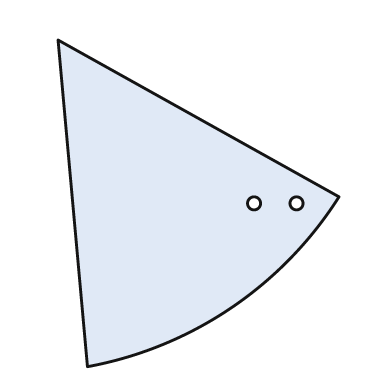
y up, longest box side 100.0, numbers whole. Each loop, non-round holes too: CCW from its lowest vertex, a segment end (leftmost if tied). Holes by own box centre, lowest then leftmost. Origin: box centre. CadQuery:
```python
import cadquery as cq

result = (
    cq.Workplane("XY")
    .moveTo(-34.0, -50.0)
    .threePointArc((10.0, -32.0), (43.0, 2.0))
    .lineTo(-43.0, 50.0)
    .close()
    .moveTo(17.0, 0.0)
    .circle(2.0)
    .moveTo(30.0, 0.0)
    .circle(2.0)
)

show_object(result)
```